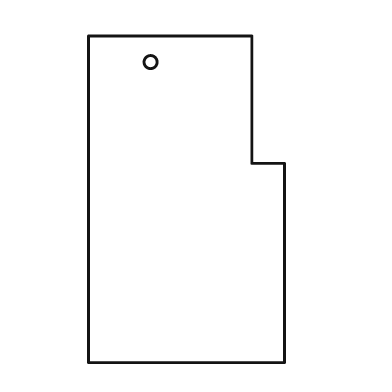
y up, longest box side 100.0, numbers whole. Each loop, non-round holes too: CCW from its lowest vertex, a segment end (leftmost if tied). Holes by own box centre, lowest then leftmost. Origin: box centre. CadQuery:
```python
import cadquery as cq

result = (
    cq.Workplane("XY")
    .moveTo(-30.0, -50.0)
    .lineTo(30.0, -50.0)
    .lineTo(30.0, 11.0)
    .lineTo(20.0, 11.0)
    .lineTo(20.0, 50.0)
    .lineTo(-30.0, 50.0)
    .close()
    .moveTo(-11.0, 42.0)
    .circle(2.0)
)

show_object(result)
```